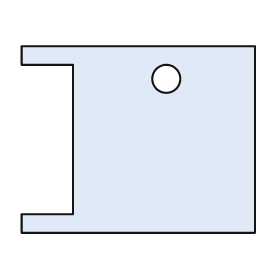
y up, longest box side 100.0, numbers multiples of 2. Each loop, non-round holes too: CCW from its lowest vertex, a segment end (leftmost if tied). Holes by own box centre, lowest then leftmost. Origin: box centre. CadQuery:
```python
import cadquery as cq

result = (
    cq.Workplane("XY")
    .moveTo(-50.0, -40.0)
    .lineTo(50.0, -40.0)
    .lineTo(50.0, 40.0)
    .lineTo(-50.0, 40.0)
    .lineTo(-50.0, 32.0)
    .lineTo(-28.0, 32.0)
    .lineTo(-28.0, -32.0)
    .lineTo(-50.0, -32.0)
    .close()
    .moveTo(12.0, 26.0)
    .circle(6.0)
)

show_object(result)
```